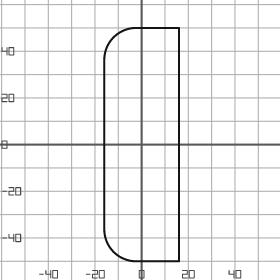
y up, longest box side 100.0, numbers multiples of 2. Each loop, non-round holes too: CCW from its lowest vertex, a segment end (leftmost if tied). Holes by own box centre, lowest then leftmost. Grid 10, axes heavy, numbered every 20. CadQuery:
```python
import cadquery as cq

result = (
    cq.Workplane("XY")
    .moveTo(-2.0, -50.0)
    .lineTo(16.0, -50.0)
    .lineTo(16.0, 50.0)
    .lineTo(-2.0, 50.0)
    .threePointArc((-12.0, 46.0), (-16.0, 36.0))
    .lineTo(-16.0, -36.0)
    .threePointArc((-12.0, -46.0), (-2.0, -50.0))
    .close()
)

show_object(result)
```